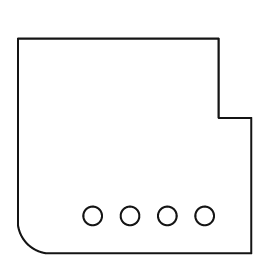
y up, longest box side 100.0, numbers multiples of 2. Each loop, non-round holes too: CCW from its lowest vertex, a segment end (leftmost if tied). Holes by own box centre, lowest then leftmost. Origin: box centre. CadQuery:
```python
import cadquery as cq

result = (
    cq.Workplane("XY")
    .moveTo(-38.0, -46.0)
    .lineTo(50.0, -46.0)
    .lineTo(50.0, 12.0)
    .lineTo(36.0, 12.0)
    .lineTo(36.0, 46.0)
    .lineTo(-50.0, 46.0)
    .lineTo(-50.0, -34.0)
    .threePointArc((-46.0, -42.0), (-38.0, -46.0))
    .close()
    .moveTo(-18.0, -30.0)
    .circle(4.0)
    .moveTo(-2.0, -30.0)
    .circle(4.0)
    .moveTo(14.0, -30.0)
    .circle(4.0)
    .moveTo(30.0, -30.0)
    .circle(4.0)
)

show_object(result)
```